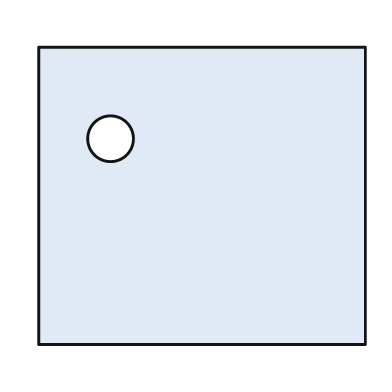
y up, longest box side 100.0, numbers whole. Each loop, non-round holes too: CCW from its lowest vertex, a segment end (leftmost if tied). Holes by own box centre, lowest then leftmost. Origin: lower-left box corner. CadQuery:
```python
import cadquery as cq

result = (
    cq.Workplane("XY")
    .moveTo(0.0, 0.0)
    .lineTo(100.0, 0.0)
    .lineTo(100.0, 91.0)
    .lineTo(0.0, 91.0)
    .close()
    .moveTo(22.0, 63.0)
    .circle(7.0)
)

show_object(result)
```